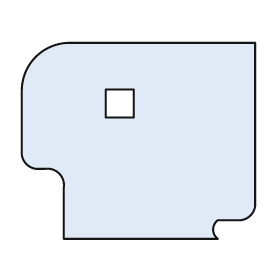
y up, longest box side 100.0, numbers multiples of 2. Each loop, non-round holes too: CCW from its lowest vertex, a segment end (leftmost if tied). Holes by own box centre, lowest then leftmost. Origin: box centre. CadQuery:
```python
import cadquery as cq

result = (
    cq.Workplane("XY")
    .moveTo(-32.0, -42.0)
    .lineTo(34.0, -42.0)
    .threePointArc((32.0, -38.0), (34.0, -34.0))
    .lineTo(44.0, -34.0)
    .threePointArc((48.0, -32.0), (50.0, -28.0))
    .lineTo(50.0, 42.0)
    .lineTo(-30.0, 42.0)
    .threePointArc((-44.0, 36.0), (-50.0, 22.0))
    .lineTo(-50.0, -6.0)
    .threePointArc((-48.0, -10.0), (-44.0, -12.0))
    .lineTo(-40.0, -12.0)
    .threePointArc((-34.0, -14.0), (-32.0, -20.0))
    .close()
    .moveTo(-14.0, 10.0)
    .lineTo(-2.0, 10.0)
    .lineTo(-2.0, 22.0)
    .lineTo(-14.0, 22.0)
    .close()
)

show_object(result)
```